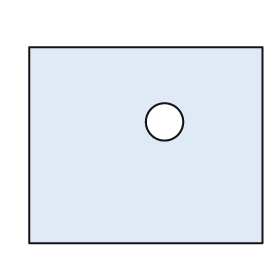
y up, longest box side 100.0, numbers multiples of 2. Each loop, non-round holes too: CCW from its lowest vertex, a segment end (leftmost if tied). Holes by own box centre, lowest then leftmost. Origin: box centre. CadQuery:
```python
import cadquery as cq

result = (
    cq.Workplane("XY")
    .moveTo(-50.0, -42.0)
    .lineTo(50.0, -42.0)
    .lineTo(50.0, 42.0)
    .lineTo(-50.0, 42.0)
    .close()
    .moveTo(8.0, 10.0)
    .circle(8.0)
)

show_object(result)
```